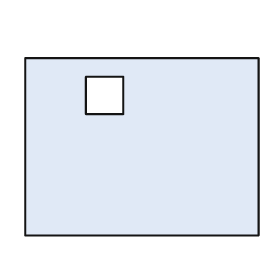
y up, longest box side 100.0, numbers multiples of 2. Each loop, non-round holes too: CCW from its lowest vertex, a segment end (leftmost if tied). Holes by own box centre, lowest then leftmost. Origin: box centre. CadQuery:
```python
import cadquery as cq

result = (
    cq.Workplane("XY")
    .moveTo(-50.0, -38.0)
    .lineTo(50.0, -38.0)
    .lineTo(50.0, 38.0)
    .lineTo(-50.0, 38.0)
    .close()
    .moveTo(-24.0, 14.0)
    .lineTo(-8.0, 14.0)
    .lineTo(-8.0, 30.0)
    .lineTo(-24.0, 30.0)
    .close()
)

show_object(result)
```